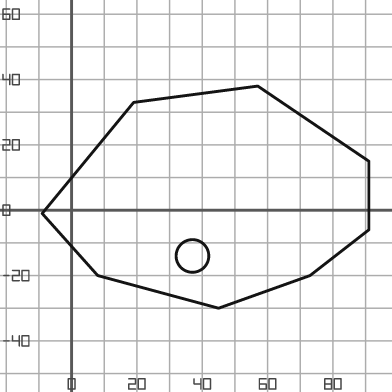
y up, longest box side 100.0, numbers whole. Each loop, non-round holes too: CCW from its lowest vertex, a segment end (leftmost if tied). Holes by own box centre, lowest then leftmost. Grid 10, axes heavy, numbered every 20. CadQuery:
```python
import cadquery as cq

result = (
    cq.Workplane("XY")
    .moveTo(45.0, -30.0)
    .lineTo(73.0, -20.0)
    .lineTo(91.0, -6.0)
    .lineTo(91.0, 15.0)
    .lineTo(57.0, 38.0)
    .lineTo(19.0, 33.0)
    .lineTo(-9.0, -1.0)
    .lineTo(8.0, -20.0)
    .close()
    .moveTo(37.0, -14.0)
    .circle(5.0)
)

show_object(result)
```